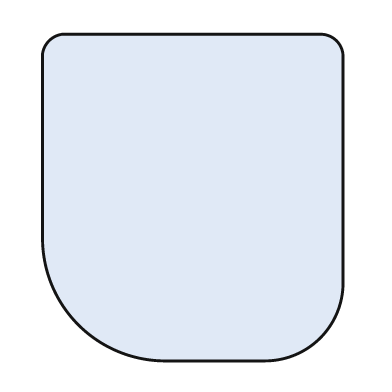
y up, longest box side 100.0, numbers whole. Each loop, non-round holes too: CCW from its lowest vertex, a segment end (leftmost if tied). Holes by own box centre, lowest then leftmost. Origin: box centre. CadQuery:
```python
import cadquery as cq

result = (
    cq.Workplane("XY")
    .moveTo(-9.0, -50.0)
    .lineTo(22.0, -50.0)
    .threePointArc((39.0, -43.0), (46.0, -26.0))
    .lineTo(46.0, 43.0)
    .threePointArc((44.0, 48.0), (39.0, 50.0))
    .lineTo(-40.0, 50.0)
    .threePointArc((-44.0, 48.0), (-46.0, 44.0))
    .lineTo(-46.0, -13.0)
    .threePointArc((-35.0, -39.0), (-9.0, -50.0))
    .close()
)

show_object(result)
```